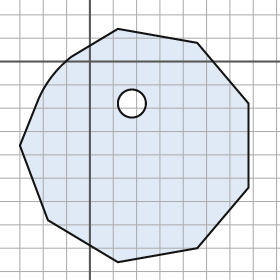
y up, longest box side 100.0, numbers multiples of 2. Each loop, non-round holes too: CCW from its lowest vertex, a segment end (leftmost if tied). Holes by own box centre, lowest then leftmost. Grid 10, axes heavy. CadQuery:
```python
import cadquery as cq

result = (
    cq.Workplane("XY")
    .moveTo(12.0, -86.0)
    .lineTo(46.0, -80.0)
    .lineTo(68.0, -54.0)
    .lineTo(68.0, -18.0)
    .lineTo(46.0, 8.0)
    .lineTo(12.0, 14.0)
    .lineTo(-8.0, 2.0)
    .threePointArc((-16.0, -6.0), (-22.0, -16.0))
    .lineTo(-30.0, -36.0)
    .lineTo(-18.0, -68.0)
    .close()
    .moveTo(18.0, -18.0)
    .circle(6.0)
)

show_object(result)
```